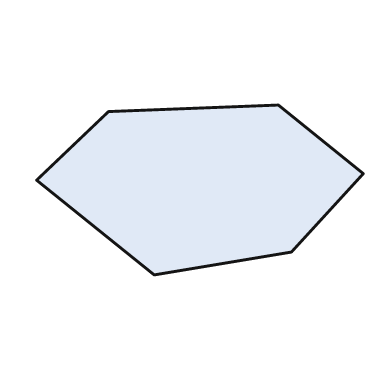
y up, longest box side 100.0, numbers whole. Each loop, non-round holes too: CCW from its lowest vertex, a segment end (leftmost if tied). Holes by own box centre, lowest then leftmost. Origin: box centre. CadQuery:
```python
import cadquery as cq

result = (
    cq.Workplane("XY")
    .moveTo(-14.0, -26.0)
    .lineTo(28.0, -19.0)
    .lineTo(50.0, 5.0)
    .lineTo(24.0, 26.0)
    .lineTo(-28.0, 24.0)
    .lineTo(-50.0, 3.0)
    .close()
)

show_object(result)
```